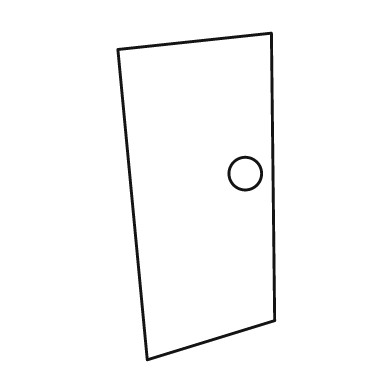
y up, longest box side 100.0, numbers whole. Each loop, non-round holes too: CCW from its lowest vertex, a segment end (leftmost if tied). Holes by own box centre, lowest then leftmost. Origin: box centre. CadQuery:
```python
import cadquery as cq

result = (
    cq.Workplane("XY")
    .moveTo(-15.0, -50.0)
    .lineTo(24.0, -38.0)
    .lineTo(23.0, 50.0)
    .lineTo(-24.0, 45.0)
    .close()
    .moveTo(15.0, 7.0)
    .circle(5.0)
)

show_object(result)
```